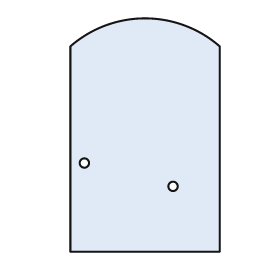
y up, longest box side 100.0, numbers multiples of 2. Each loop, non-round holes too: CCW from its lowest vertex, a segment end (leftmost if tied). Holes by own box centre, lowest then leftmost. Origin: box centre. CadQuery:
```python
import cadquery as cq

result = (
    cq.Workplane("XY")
    .moveTo(-32.0, -50.0)
    .lineTo(32.0, -50.0)
    .lineTo(32.0, 38.0)
    .threePointArc((0.0, 50.0), (-32.0, 38.0))
    .close()
    .moveTo(12.0, -22.0)
    .circle(2.0)
    .moveTo(-26.0, -12.0)
    .circle(2.0)
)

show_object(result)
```